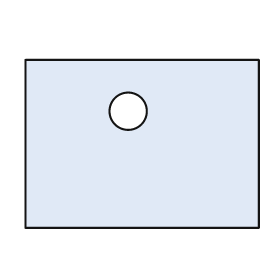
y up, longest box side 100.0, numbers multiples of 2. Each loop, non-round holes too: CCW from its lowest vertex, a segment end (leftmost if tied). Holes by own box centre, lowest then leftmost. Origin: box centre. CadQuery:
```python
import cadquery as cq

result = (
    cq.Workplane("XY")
    .moveTo(-50.0, -36.0)
    .lineTo(50.0, -36.0)
    .lineTo(50.0, 36.0)
    .lineTo(-50.0, 36.0)
    .close()
    .moveTo(-6.0, 14.0)
    .circle(8.0)
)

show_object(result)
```